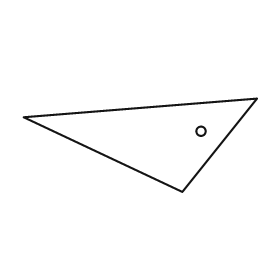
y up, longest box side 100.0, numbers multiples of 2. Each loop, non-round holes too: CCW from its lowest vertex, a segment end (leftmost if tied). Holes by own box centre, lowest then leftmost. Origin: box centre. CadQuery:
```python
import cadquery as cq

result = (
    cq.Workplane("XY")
    .moveTo(18.0, -20.0)
    .lineTo(50.0, 20.0)
    .lineTo(-50.0, 12.0)
    .close()
    .moveTo(26.0, 6.0)
    .circle(2.0)
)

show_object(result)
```